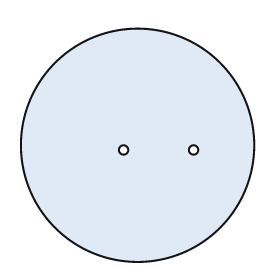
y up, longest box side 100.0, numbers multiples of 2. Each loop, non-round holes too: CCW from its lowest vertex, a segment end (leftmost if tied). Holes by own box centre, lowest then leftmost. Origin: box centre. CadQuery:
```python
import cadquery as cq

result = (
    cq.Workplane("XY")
    .moveTo(0.0, 0.0)
    .circle(50.0)
    .moveTo(-6.0, -2.0)
    .circle(2.0)
    .moveTo(24.0, -2.0)
    .circle(2.0)
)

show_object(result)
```